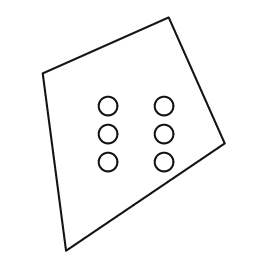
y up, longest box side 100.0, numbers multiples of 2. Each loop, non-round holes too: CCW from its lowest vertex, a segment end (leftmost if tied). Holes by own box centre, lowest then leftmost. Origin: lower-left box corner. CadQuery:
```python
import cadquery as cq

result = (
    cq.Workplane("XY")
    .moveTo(10.0, 0.0)
    .lineTo(78.0, 46.0)
    .lineTo(54.0, 100.0)
    .lineTo(0.0, 76.0)
    .close()
    .moveTo(28.0, 38.0)
    .circle(4.0)
    .moveTo(52.0, 38.0)
    .circle(4.0)
    .moveTo(28.0, 50.0)
    .circle(4.0)
    .moveTo(52.0, 50.0)
    .circle(4.0)
    .moveTo(28.0, 62.0)
    .circle(4.0)
    .moveTo(52.0, 62.0)
    .circle(4.0)
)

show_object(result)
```